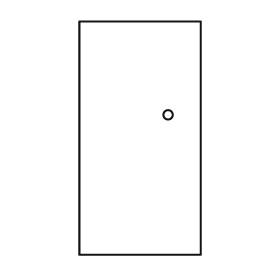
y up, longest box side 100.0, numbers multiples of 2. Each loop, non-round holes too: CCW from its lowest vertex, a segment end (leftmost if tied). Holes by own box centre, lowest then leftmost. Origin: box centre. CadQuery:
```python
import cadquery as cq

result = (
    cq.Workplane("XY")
    .moveTo(-26.0, -50.0)
    .lineTo(26.0, -50.0)
    .lineTo(26.0, 50.0)
    .lineTo(-26.0, 50.0)
    .close()
    .moveTo(12.0, 10.0)
    .circle(2.0)
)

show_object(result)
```